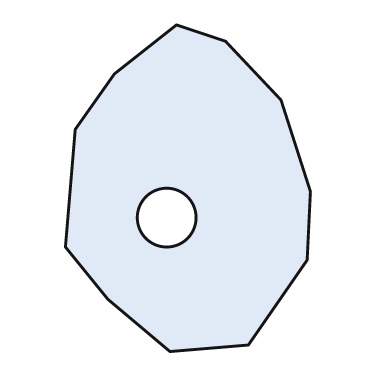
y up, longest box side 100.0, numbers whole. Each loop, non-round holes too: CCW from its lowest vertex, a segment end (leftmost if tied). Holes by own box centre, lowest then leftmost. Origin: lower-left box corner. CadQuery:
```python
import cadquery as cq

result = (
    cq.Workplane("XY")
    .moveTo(32.0, 0.0)
    .lineTo(56.0, 2.0)
    .lineTo(74.0, 28.0)
    .lineTo(75.0, 49.0)
    .lineTo(66.0, 77.0)
    .lineTo(49.0, 95.0)
    .lineTo(34.0, 100.0)
    .lineTo(15.0, 85.0)
    .lineTo(3.0, 68.0)
    .lineTo(0.0, 32.0)
    .lineTo(13.0, 16.0)
    .close()
    .moveTo(31.0, 41.0)
    .circle(9.0)
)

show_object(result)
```